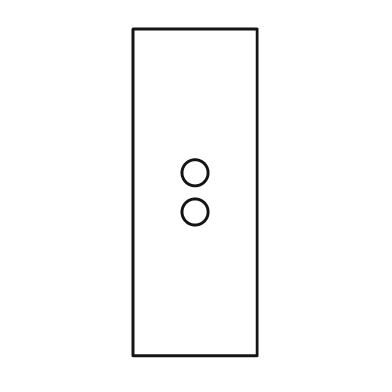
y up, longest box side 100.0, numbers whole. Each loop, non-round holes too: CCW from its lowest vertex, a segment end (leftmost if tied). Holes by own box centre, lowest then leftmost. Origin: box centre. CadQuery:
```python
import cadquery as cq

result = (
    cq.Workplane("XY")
    .moveTo(-19.0, -50.0)
    .lineTo(19.0, -50.0)
    .lineTo(19.0, 50.0)
    .lineTo(-19.0, 50.0)
    .close()
    .moveTo(0.0, -6.0)
    .circle(4.0)
    .moveTo(0.0, 6.0)
    .circle(4.0)
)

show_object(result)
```